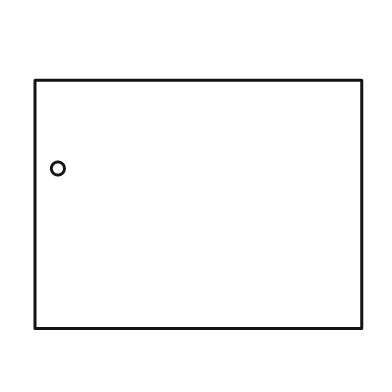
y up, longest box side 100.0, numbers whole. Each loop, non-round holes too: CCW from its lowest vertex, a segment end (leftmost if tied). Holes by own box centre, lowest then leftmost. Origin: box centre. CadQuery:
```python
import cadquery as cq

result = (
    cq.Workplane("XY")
    .moveTo(-50.0, -38.0)
    .lineTo(50.0, -38.0)
    .lineTo(50.0, 38.0)
    .lineTo(-50.0, 38.0)
    .close()
    .moveTo(-43.0, 11.0)
    .circle(2.0)
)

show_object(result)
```